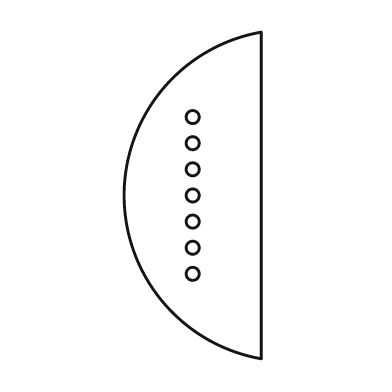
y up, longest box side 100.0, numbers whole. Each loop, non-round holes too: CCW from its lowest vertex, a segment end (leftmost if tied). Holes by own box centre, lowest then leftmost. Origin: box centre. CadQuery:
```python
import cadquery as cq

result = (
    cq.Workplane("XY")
    .moveTo(21.0, -50.0)
    .lineTo(21.0, 50.0)
    .threePointArc((-21.0, 0.0), (21.0, -50.0))
    .close()
    .moveTo(0.0, -24.0)
    .circle(2.0)
    .moveTo(0.0, -16.0)
    .circle(2.0)
    .moveTo(0.0, -8.0)
    .circle(2.0)
    .moveTo(0.0, 0.0)
    .circle(2.0)
    .moveTo(0.0, 8.0)
    .circle(2.0)
    .moveTo(0.0, 16.0)
    .circle(2.0)
    .moveTo(0.0, 24.0)
    .circle(2.0)
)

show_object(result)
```